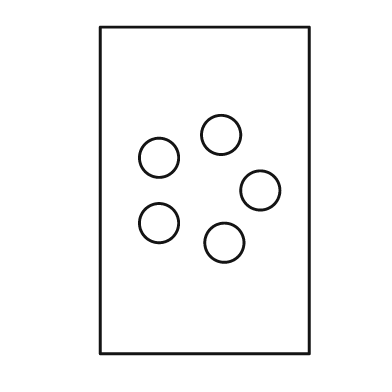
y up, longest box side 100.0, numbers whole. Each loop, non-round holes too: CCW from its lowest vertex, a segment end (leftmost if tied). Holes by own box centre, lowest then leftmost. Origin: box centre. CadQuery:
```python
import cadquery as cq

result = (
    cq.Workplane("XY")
    .moveTo(-32.0, -50.0)
    .lineTo(32.0, -50.0)
    .lineTo(32.0, 50.0)
    .lineTo(-32.0, 50.0)
    .close()
    .moveTo(6.0, -16.0)
    .circle(6.0)
    .moveTo(-14.0, -10.0)
    .circle(6.0)
    .moveTo(17.0, 0.0)
    .circle(6.0)
    .moveTo(-14.0, 10.0)
    .circle(6.0)
    .moveTo(5.0, 17.0)
    .circle(6.0)
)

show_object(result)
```